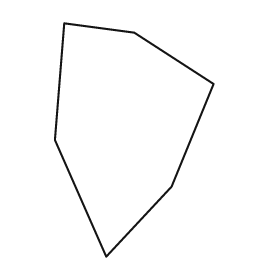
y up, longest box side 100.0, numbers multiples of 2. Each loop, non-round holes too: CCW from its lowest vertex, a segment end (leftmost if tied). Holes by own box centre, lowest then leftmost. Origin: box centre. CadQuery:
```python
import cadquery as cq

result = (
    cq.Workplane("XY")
    .moveTo(-12.0, -50.0)
    .lineTo(16.0, -20.0)
    .lineTo(34.0, 24.0)
    .lineTo(0.0, 46.0)
    .lineTo(-30.0, 50.0)
    .lineTo(-34.0, 0.0)
    .close()
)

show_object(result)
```